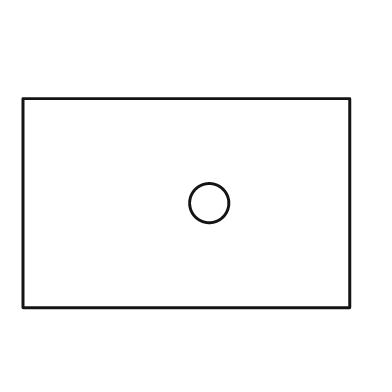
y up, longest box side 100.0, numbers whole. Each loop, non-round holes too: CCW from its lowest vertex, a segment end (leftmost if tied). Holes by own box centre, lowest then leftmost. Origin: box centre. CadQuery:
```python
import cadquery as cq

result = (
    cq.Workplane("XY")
    .moveTo(-50.0, -32.0)
    .lineTo(50.0, -32.0)
    .lineTo(50.0, 32.0)
    .lineTo(-50.0, 32.0)
    .close()
    .moveTo(7.0, 0.0)
    .circle(6.0)
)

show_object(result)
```